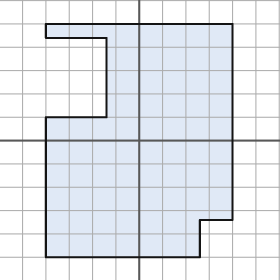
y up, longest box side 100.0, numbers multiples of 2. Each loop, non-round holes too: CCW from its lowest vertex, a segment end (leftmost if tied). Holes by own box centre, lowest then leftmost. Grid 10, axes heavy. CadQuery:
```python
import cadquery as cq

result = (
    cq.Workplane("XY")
    .moveTo(-40.0, -50.0)
    .lineTo(26.0, -50.0)
    .lineTo(26.0, -34.0)
    .lineTo(40.0, -34.0)
    .lineTo(40.0, 50.0)
    .lineTo(-40.0, 50.0)
    .lineTo(-40.0, 44.0)
    .lineTo(-14.0, 44.0)
    .lineTo(-14.0, 10.0)
    .lineTo(-40.0, 10.0)
    .close()
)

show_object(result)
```